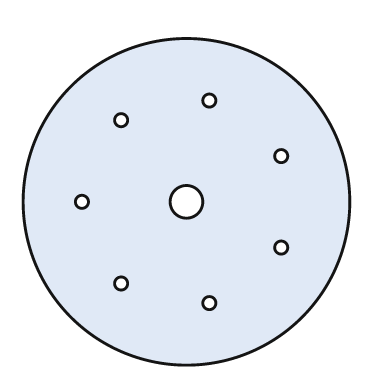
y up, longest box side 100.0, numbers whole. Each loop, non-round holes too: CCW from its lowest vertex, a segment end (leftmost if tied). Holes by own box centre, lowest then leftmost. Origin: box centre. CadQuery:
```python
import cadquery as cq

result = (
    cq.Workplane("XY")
    .moveTo(0.0, 0.0)
    .circle(50.0)
    .moveTo(7.0, -31.0)
    .circle(2.0)
    .moveTo(-20.0, -25.0)
    .circle(2.0)
    .moveTo(29.0, -14.0)
    .circle(2.0)
    .moveTo(-32.0, 0.0)
    .circle(2.0)
    .moveTo(0.0, 0.0)
    .circle(5.0)
    .moveTo(29.0, 14.0)
    .circle(2.0)
    .moveTo(-20.0, 25.0)
    .circle(2.0)
    .moveTo(7.0, 31.0)
    .circle(2.0)
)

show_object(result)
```